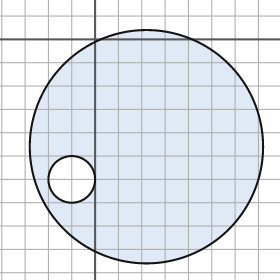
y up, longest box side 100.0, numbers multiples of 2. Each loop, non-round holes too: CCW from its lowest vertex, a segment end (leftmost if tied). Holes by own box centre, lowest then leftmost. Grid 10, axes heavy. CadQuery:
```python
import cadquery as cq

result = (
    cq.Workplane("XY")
    .moveTo(22.0, -46.0)
    .circle(50.0)
    .moveTo(-10.0, -60.0)
    .circle(10.0)
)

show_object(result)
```